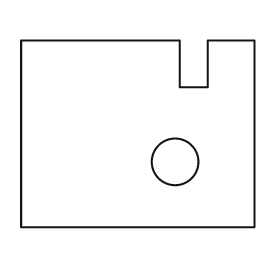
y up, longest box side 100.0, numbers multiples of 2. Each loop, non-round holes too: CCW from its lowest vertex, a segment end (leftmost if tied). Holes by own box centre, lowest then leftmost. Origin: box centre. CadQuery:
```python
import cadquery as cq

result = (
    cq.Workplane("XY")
    .moveTo(-50.0, -40.0)
    .lineTo(50.0, -40.0)
    .lineTo(50.0, 40.0)
    .lineTo(30.0, 40.0)
    .lineTo(30.0, 20.0)
    .lineTo(18.0, 20.0)
    .lineTo(18.0, 40.0)
    .lineTo(-50.0, 40.0)
    .close()
    .moveTo(16.0, -12.0)
    .circle(10.0)
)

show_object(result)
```